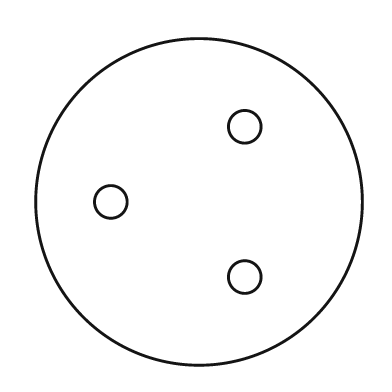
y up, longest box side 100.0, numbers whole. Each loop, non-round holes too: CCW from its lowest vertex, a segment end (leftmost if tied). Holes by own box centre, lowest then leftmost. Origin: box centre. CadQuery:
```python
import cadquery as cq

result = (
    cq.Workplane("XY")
    .moveTo(0.0, 0.0)
    .circle(50.0)
    .moveTo(14.0, -23.0)
    .circle(5.0)
    .moveTo(-27.0, 0.0)
    .circle(5.0)
    .moveTo(14.0, 23.0)
    .circle(5.0)
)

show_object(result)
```